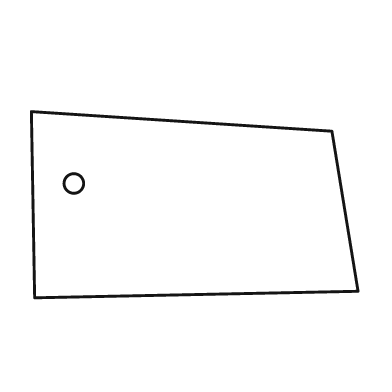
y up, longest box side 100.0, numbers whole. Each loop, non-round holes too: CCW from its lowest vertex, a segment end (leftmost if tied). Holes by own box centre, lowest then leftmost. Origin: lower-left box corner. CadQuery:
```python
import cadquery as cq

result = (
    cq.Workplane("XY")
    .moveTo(1.0, 0.0)
    .lineTo(100.0, 2.0)
    .lineTo(92.0, 51.0)
    .lineTo(0.0, 57.0)
    .close()
    .moveTo(13.0, 35.0)
    .circle(3.0)
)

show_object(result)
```